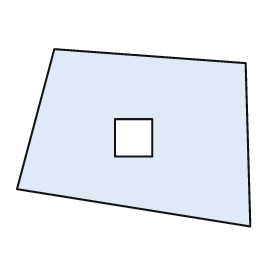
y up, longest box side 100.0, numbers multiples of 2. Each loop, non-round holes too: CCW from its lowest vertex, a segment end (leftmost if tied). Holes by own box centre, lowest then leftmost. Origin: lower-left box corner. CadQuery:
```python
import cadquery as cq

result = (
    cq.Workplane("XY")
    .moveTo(100.0, 0.0)
    .lineTo(98.0, 70.0)
    .lineTo(16.0, 76.0)
    .lineTo(0.0, 16.0)
    .close()
    .moveTo(42.0, 30.0)
    .lineTo(58.0, 30.0)
    .lineTo(58.0, 46.0)
    .lineTo(42.0, 46.0)
    .close()
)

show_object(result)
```